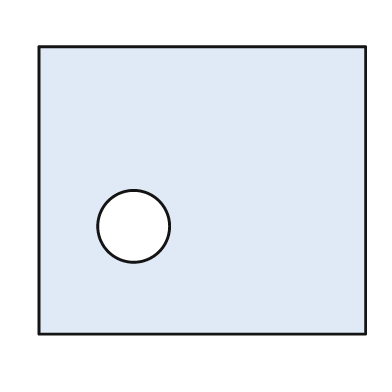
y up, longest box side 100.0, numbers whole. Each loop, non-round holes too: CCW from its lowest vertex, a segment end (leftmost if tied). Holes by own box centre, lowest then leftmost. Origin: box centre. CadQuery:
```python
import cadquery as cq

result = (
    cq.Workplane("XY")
    .moveTo(-50.0, -44.0)
    .lineTo(50.0, -44.0)
    .lineTo(50.0, 44.0)
    .lineTo(-50.0, 44.0)
    .close()
    .moveTo(-21.0, -11.0)
    .circle(11.0)
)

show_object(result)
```